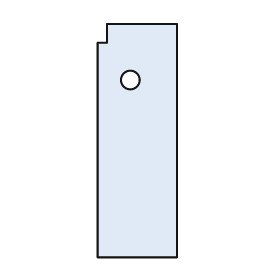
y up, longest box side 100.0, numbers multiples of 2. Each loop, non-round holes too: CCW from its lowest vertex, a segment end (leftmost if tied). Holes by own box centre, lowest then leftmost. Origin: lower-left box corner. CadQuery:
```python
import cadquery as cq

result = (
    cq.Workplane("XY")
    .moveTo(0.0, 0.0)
    .lineTo(34.0, 0.0)
    .lineTo(34.0, 100.0)
    .lineTo(4.0, 100.0)
    .lineTo(4.0, 92.0)
    .lineTo(0.0, 92.0)
    .close()
    .moveTo(14.0, 76.0)
    .circle(4.0)
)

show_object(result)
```